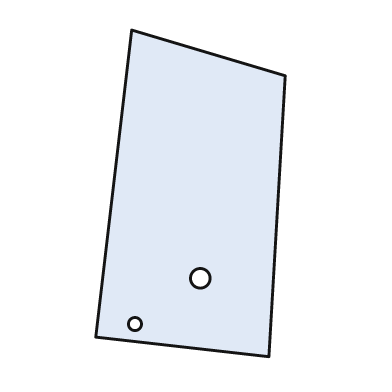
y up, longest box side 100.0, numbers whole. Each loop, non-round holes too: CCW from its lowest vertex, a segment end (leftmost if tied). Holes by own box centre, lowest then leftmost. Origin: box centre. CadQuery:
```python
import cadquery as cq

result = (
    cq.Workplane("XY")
    .moveTo(24.0, -50.0)
    .lineTo(29.0, 36.0)
    .lineTo(-18.0, 50.0)
    .lineTo(-29.0, -44.0)
    .close()
    .moveTo(-17.0, -40.0)
    .circle(2.0)
    .moveTo(3.0, -26.0)
    .circle(3.0)
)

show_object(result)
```